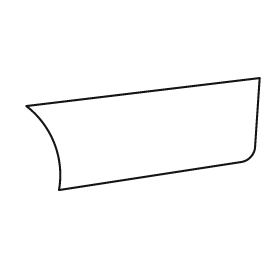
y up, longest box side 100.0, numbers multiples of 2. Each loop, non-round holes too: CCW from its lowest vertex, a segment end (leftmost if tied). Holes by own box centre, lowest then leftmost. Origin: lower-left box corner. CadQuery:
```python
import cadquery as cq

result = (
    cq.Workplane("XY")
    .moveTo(14.0, 0.0)
    .lineTo(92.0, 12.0)
    .threePointArc((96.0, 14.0), (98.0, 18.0))
    .lineTo(100.0, 48.0)
    .lineTo(0.0, 36.0)
    .threePointArc((12.0, 20.0), (14.0, 0.0))
    .close()
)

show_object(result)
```